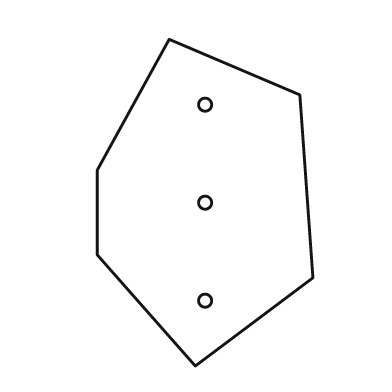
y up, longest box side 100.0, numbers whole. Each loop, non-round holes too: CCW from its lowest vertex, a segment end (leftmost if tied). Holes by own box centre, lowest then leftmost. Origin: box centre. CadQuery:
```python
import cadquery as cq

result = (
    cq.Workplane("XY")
    .moveTo(-3.0, -50.0)
    .lineTo(33.0, -23.0)
    .lineTo(29.0, 33.0)
    .lineTo(-11.0, 50.0)
    .lineTo(-33.0, 10.0)
    .lineTo(-33.0, -16.0)
    .close()
    .moveTo(0.0, -30.0)
    .circle(2.0)
    .moveTo(0.0, 0.0)
    .circle(2.0)
    .moveTo(0.0, 30.0)
    .circle(2.0)
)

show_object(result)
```